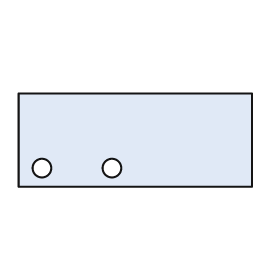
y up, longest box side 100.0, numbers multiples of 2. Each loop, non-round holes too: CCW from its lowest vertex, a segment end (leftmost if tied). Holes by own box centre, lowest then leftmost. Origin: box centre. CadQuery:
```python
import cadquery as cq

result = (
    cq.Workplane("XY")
    .moveTo(-50.0, -20.0)
    .lineTo(50.0, -20.0)
    .lineTo(50.0, 20.0)
    .lineTo(-50.0, 20.0)
    .close()
    .moveTo(-40.0, -12.0)
    .circle(4.0)
    .moveTo(-10.0, -12.0)
    .circle(4.0)
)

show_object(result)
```